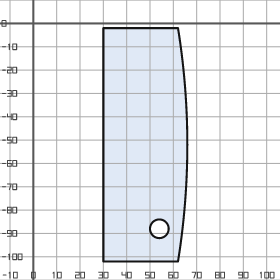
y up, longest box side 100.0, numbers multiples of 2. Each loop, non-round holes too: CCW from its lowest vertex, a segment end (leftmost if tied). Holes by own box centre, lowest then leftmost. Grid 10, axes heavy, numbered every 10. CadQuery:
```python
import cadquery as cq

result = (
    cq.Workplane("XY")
    .moveTo(30.0, -102.0)
    .lineTo(62.0, -102.0)
    .threePointArc((66.0, -52.0), (62.0, -2.0))
    .lineTo(30.0, -2.0)
    .close()
    .moveTo(54.0, -88.0)
    .circle(4.0)
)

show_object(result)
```